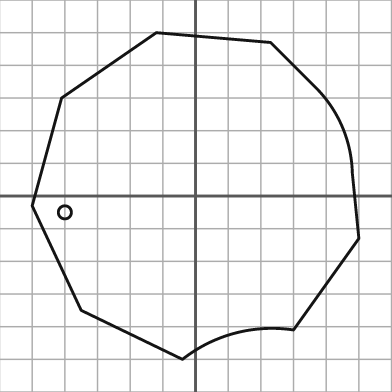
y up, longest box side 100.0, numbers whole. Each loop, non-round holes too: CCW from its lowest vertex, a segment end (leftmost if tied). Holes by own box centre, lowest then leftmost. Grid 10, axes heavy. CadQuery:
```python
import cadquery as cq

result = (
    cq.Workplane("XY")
    .moveTo(-4.0, -50.0)
    .threePointArc((12.0, -42.0), (30.0, -41.0))
    .lineTo(50.0, -13.0)
    .lineTo(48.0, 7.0)
    .threePointArc((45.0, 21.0), (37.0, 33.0))
    .lineTo(23.0, 47.0)
    .lineTo(-12.0, 50.0)
    .lineTo(-41.0, 30.0)
    .lineTo(-50.0, -3.0)
    .lineTo(-35.0, -35.0)
    .close()
    .moveTo(-40.0, -5.0)
    .circle(2.0)
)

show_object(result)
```